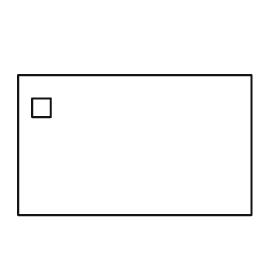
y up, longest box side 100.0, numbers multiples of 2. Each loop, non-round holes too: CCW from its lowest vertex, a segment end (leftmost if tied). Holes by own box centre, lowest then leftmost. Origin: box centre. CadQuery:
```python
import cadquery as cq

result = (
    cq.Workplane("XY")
    .moveTo(-50.0, -30.0)
    .lineTo(50.0, -30.0)
    .lineTo(50.0, 30.0)
    .lineTo(-50.0, 30.0)
    .close()
    .moveTo(-44.0, 12.0)
    .lineTo(-36.0, 12.0)
    .lineTo(-36.0, 20.0)
    .lineTo(-44.0, 20.0)
    .close()
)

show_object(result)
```